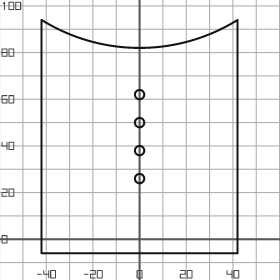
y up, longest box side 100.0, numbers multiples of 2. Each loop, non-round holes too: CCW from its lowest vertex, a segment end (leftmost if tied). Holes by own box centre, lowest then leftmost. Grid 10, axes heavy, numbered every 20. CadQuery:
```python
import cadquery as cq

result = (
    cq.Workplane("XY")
    .moveTo(-42.0, -6.0)
    .lineTo(42.0, -6.0)
    .lineTo(42.0, 94.0)
    .threePointArc((0.0, 82.0), (-42.0, 94.0))
    .close()
    .moveTo(0.0, 26.0)
    .circle(2.0)
    .moveTo(0.0, 38.0)
    .circle(2.0)
    .moveTo(0.0, 50.0)
    .circle(2.0)
    .moveTo(0.0, 62.0)
    .circle(2.0)
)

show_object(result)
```